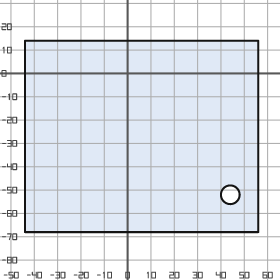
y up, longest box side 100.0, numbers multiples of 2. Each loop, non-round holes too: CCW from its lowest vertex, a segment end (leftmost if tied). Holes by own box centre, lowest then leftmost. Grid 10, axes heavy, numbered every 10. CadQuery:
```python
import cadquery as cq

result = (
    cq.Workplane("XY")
    .moveTo(-44.0, -68.0)
    .lineTo(56.0, -68.0)
    .lineTo(56.0, 14.0)
    .lineTo(-44.0, 14.0)
    .close()
    .moveTo(44.0, -52.0)
    .circle(4.0)
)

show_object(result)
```